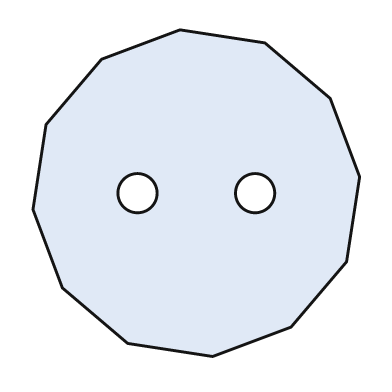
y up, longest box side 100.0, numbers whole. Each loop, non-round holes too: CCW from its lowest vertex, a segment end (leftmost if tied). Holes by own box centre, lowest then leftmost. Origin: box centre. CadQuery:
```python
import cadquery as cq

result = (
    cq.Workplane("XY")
    .moveTo(5.0, -50.0)
    .lineTo(29.0, -41.0)
    .lineTo(46.0, -21.0)
    .lineTo(50.0, 5.0)
    .lineTo(41.0, 29.0)
    .lineTo(21.0, 46.0)
    .lineTo(-5.0, 50.0)
    .lineTo(-29.0, 41.0)
    .lineTo(-46.0, 21.0)
    .lineTo(-50.0, -5.0)
    .lineTo(-41.0, -29.0)
    .lineTo(-21.0, -46.0)
    .close()
    .moveTo(-18.0, 0.0)
    .circle(6.0)
    .moveTo(18.0, 0.0)
    .circle(6.0)
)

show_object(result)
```